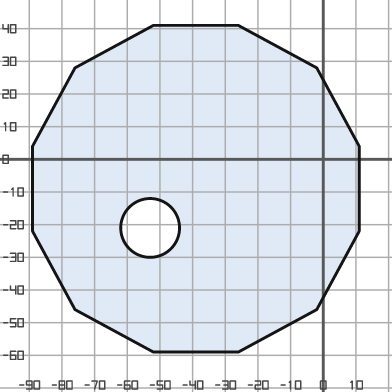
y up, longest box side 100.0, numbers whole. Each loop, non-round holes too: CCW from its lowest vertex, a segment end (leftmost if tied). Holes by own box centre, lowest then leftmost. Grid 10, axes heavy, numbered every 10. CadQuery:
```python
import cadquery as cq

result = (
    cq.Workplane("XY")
    .moveTo(-52.0, -59.0)
    .lineTo(-26.0, -59.0)
    .lineTo(-2.0, -46.0)
    .lineTo(11.0, -22.0)
    .lineTo(11.0, 4.0)
    .lineTo(-2.0, 28.0)
    .lineTo(-26.0, 41.0)
    .lineTo(-52.0, 41.0)
    .lineTo(-76.0, 28.0)
    .lineTo(-89.0, 4.0)
    .lineTo(-89.0, -22.0)
    .lineTo(-76.0, -46.0)
    .close()
    .moveTo(-53.0, -21.0)
    .circle(9.0)
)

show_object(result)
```